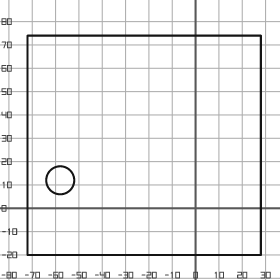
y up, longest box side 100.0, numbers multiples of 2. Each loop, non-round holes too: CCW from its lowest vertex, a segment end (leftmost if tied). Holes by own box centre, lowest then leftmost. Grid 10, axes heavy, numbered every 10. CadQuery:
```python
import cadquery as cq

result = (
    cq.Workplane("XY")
    .moveTo(-72.0, -20.0)
    .lineTo(28.0, -20.0)
    .lineTo(28.0, 74.0)
    .lineTo(-72.0, 74.0)
    .close()
    .moveTo(-58.0, 12.0)
    .circle(6.0)
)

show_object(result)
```